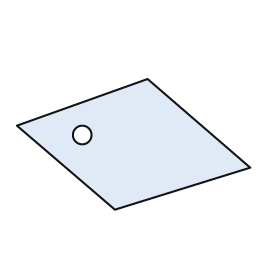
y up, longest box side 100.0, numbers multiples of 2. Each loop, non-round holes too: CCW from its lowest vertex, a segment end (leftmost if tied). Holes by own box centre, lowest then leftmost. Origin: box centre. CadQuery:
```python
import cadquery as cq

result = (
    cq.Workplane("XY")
    .moveTo(-8.0, -28.0)
    .lineTo(50.0, -10.0)
    .lineTo(6.0, 28.0)
    .lineTo(-50.0, 8.0)
    .close()
    .moveTo(-22.0, 4.0)
    .circle(4.0)
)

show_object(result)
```